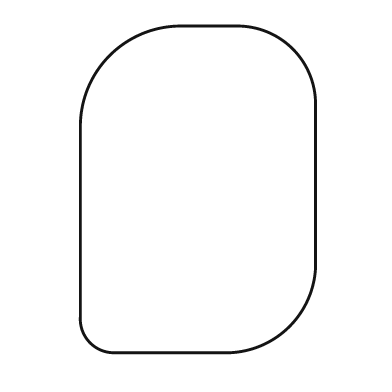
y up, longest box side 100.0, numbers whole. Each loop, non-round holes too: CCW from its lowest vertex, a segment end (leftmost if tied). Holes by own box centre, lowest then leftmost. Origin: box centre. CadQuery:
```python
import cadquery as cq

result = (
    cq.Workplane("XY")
    .moveTo(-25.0, -50.0)
    .lineTo(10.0, -50.0)
    .threePointArc((28.0, -42.0), (36.0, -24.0))
    .lineTo(36.0, 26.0)
    .threePointArc((29.0, 43.0), (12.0, 50.0))
    .lineTo(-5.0, 50.0)
    .threePointArc((-27.0, 41.0), (-36.0, 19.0))
    .lineTo(-36.0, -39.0)
    .threePointArc((-33.0, -47.0), (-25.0, -50.0))
    .close()
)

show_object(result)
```